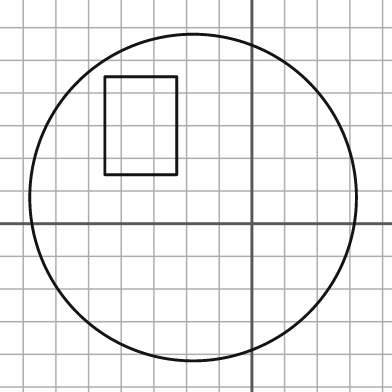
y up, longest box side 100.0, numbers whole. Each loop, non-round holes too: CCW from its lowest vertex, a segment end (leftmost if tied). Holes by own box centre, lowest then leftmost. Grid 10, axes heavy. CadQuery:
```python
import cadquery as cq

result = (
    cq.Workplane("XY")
    .moveTo(-18.0, 8.0)
    .circle(50.0)
    .moveTo(-45.0, 15.0)
    .lineTo(-23.0, 15.0)
    .lineTo(-23.0, 45.0)
    .lineTo(-45.0, 45.0)
    .close()
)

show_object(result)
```